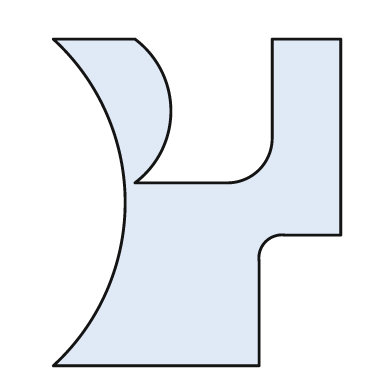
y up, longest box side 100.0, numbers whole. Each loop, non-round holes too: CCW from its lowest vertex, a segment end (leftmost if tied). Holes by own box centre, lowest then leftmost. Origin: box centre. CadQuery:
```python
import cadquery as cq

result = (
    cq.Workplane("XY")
    .moveTo(-44.0, -50.0)
    .lineTo(19.0, -50.0)
    .lineTo(19.0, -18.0)
    .threePointArc((21.0, -12.0), (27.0, -10.0))
    .lineTo(44.0, -10.0)
    .lineTo(44.0, 50.0)
    .lineTo(23.0, 50.0)
    .lineTo(23.0, 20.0)
    .threePointArc((19.0, 10.0), (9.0, 6.0))
    .lineTo(-19.0, 6.0)
    .threePointArc((-8.0, 28.0), (-19.0, 50.0))
    .lineTo(-44.0, 50.0)
    .threePointArc((-22.0, 0.0), (-44.0, -50.0))
    .close()
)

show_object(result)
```